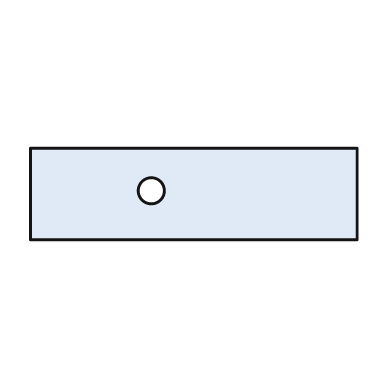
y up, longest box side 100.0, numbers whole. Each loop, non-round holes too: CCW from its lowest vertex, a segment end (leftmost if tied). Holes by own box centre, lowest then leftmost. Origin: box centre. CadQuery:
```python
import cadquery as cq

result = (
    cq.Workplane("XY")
    .moveTo(-50.0, -14.0)
    .lineTo(50.0, -14.0)
    .lineTo(50.0, 14.0)
    .lineTo(-50.0, 14.0)
    .close()
    .moveTo(-13.0, 1.0)
    .circle(4.0)
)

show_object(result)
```